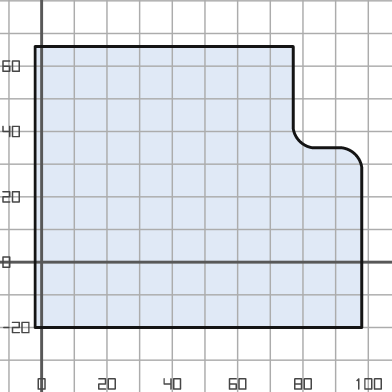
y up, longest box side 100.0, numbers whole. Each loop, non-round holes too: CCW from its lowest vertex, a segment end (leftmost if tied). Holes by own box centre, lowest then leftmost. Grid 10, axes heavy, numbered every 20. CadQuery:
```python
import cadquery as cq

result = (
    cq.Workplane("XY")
    .moveTo(-2.0, -20.0)
    .lineTo(98.0, -20.0)
    .lineTo(98.0, 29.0)
    .threePointArc((96.0, 33.0), (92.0, 35.0))
    .lineTo(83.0, 35.0)
    .threePointArc((79.0, 37.0), (77.0, 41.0))
    .lineTo(77.0, 66.0)
    .lineTo(-2.0, 66.0)
    .close()
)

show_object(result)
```